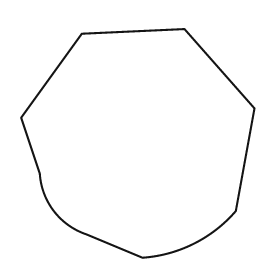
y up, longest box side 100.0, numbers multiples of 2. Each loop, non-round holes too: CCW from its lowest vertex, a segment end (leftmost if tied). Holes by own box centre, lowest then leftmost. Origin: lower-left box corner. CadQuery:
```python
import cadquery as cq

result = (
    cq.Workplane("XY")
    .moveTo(52.0, 0.0)
    .threePointArc((74.0, 6.0), (92.0, 20.0))
    .lineTo(100.0, 64.0)
    .lineTo(70.0, 98.0)
    .lineTo(26.0, 96.0)
    .lineTo(0.0, 60.0)
    .lineTo(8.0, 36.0)
    .threePointArc((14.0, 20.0), (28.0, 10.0))
    .close()
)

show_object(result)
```